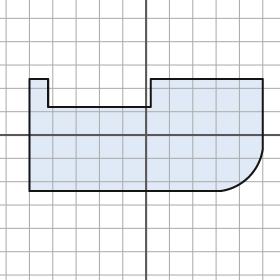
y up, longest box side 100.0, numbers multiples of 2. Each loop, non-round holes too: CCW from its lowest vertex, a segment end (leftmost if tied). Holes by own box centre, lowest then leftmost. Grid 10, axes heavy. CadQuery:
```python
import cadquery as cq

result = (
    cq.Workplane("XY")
    .moveTo(-50.0, -24.0)
    .lineTo(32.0, -24.0)
    .threePointArc((44.0, -18.0), (50.0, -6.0))
    .lineTo(50.0, 24.0)
    .lineTo(2.0, 24.0)
    .lineTo(2.0, 12.0)
    .lineTo(-42.0, 12.0)
    .lineTo(-42.0, 24.0)
    .lineTo(-50.0, 24.0)
    .close()
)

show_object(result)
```